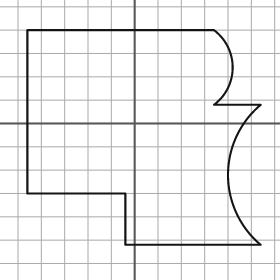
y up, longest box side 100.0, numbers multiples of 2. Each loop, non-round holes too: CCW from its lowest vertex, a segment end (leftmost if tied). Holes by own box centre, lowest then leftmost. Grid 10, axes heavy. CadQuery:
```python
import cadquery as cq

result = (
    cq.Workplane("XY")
    .moveTo(-4.0, -52.0)
    .lineTo(54.0, -52.0)
    .threePointArc((40.0, -22.0), (54.0, 8.0))
    .lineTo(34.0, 8.0)
    .threePointArc((42.0, 24.0), (34.0, 40.0))
    .lineTo(-46.0, 40.0)
    .lineTo(-46.0, -30.0)
    .lineTo(-4.0, -30.0)
    .close()
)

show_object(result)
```